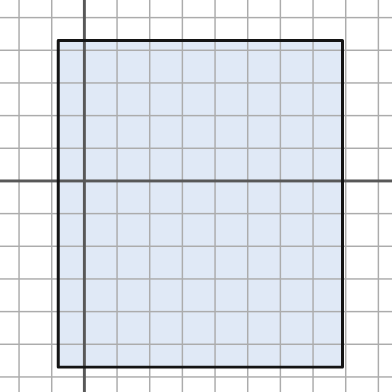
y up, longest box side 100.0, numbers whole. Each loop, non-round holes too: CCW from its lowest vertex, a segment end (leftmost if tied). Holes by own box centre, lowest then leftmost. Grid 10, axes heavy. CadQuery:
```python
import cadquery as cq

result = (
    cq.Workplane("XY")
    .moveTo(-8.0, -57.0)
    .lineTo(79.0, -57.0)
    .lineTo(79.0, 43.0)
    .lineTo(-8.0, 43.0)
    .close()
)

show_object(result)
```